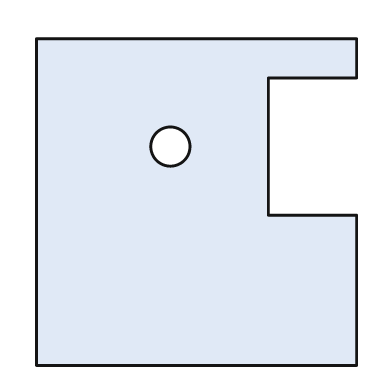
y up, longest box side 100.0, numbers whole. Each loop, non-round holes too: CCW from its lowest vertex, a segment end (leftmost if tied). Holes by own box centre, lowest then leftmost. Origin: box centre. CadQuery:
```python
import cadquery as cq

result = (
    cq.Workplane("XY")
    .moveTo(-49.0, -50.0)
    .lineTo(49.0, -50.0)
    .lineTo(49.0, -4.0)
    .lineTo(22.0, -4.0)
    .lineTo(22.0, 38.0)
    .lineTo(49.0, 38.0)
    .lineTo(49.0, 50.0)
    .lineTo(-49.0, 50.0)
    .close()
    .moveTo(-8.0, 17.0)
    .circle(6.0)
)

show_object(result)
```